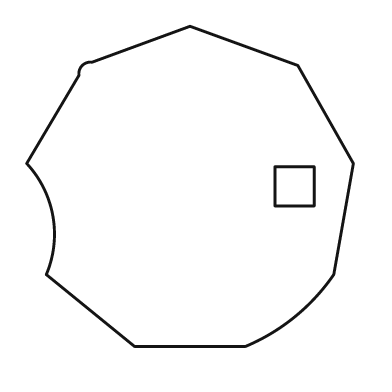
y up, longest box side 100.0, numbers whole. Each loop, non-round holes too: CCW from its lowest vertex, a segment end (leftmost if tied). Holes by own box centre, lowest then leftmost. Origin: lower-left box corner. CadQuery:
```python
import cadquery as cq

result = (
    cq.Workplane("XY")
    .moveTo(33.0, 0.0)
    .lineTo(67.0, 0.0)
    .threePointArc((82.0, 9.0), (94.0, 22.0))
    .lineTo(100.0, 56.0)
    .lineTo(83.0, 86.0)
    .lineTo(50.0, 98.0)
    .lineTo(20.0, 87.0)
    .threePointArc((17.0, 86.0), (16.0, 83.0))
    .lineTo(0.0, 56.0)
    .threePointArc((8.0, 40.0), (6.0, 22.0))
    .close()
    .moveTo(76.0, 43.0)
    .lineTo(88.0, 43.0)
    .lineTo(88.0, 55.0)
    .lineTo(76.0, 55.0)
    .close()
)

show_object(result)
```